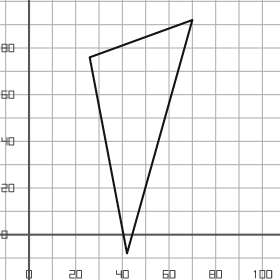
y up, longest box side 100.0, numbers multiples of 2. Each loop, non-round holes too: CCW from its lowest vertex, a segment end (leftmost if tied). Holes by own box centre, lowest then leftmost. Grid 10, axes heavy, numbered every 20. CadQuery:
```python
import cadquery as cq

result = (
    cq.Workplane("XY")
    .moveTo(42.0, -8.0)
    .lineTo(70.0, 92.0)
    .lineTo(26.0, 76.0)
    .close()
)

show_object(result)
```